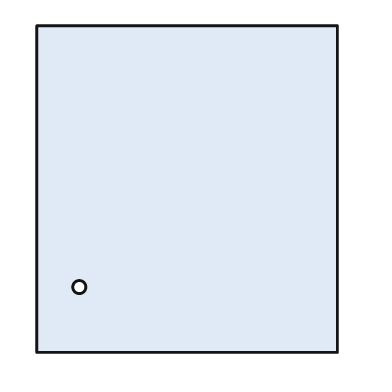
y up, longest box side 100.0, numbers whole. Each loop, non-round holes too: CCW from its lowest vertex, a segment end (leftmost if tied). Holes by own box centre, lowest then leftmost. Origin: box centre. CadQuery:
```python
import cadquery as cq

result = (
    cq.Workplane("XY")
    .moveTo(-46.0, -50.0)
    .lineTo(46.0, -50.0)
    .lineTo(46.0, 50.0)
    .lineTo(-46.0, 50.0)
    .close()
    .moveTo(-33.0, -30.0)
    .circle(2.0)
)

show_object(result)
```